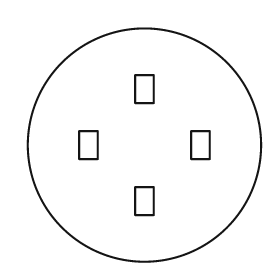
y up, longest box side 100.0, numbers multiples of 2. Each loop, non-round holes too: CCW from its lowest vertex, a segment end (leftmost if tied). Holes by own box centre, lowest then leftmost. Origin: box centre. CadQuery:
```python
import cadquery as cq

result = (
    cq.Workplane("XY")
    .moveTo(0.0, 0.0)
    .circle(50.0)
    .moveTo(-4.0, -30.0)
    .lineTo(4.0, -30.0)
    .lineTo(4.0, -18.0)
    .lineTo(-4.0, -18.0)
    .close()
    .moveTo(-28.0, -6.0)
    .lineTo(-20.0, -6.0)
    .lineTo(-20.0, 6.0)
    .lineTo(-28.0, 6.0)
    .close()
    .moveTo(20.0, -6.0)
    .lineTo(28.0, -6.0)
    .lineTo(28.0, 6.0)
    .lineTo(20.0, 6.0)
    .close()
    .moveTo(-4.0, 18.0)
    .lineTo(4.0, 18.0)
    .lineTo(4.0, 30.0)
    .lineTo(-4.0, 30.0)
    .close()
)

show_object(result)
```